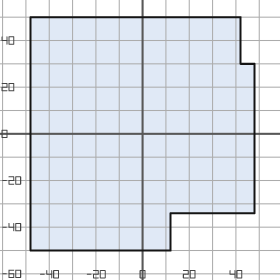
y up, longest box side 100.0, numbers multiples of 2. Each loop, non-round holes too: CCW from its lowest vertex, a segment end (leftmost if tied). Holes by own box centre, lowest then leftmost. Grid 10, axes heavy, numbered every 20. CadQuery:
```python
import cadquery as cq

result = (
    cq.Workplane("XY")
    .moveTo(-48.0, -50.0)
    .lineTo(12.0, -50.0)
    .lineTo(12.0, -34.0)
    .lineTo(48.0, -34.0)
    .lineTo(48.0, 30.0)
    .lineTo(42.0, 30.0)
    .lineTo(42.0, 50.0)
    .lineTo(-48.0, 50.0)
    .close()
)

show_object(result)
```